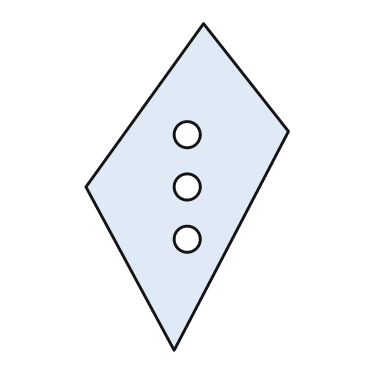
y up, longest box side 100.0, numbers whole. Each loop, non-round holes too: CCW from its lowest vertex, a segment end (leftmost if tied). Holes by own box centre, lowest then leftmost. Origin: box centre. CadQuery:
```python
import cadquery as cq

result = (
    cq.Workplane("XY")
    .moveTo(-4.0, -50.0)
    .lineTo(31.0, 17.0)
    .lineTo(5.0, 50.0)
    .lineTo(-31.0, 0.0)
    .close()
    .moveTo(0.0, -16.0)
    .circle(4.0)
    .moveTo(0.0, 0.0)
    .circle(4.0)
    .moveTo(0.0, 16.0)
    .circle(4.0)
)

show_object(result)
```